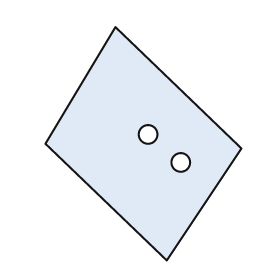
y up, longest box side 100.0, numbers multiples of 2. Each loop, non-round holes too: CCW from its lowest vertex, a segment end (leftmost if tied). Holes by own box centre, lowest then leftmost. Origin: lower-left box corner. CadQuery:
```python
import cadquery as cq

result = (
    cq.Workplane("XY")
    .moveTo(52.0, 0.0)
    .lineTo(84.0, 48.0)
    .lineTo(30.0, 100.0)
    .lineTo(0.0, 50.0)
    .close()
    .moveTo(58.0, 42.0)
    .circle(4.0)
    .moveTo(44.0, 54.0)
    .circle(4.0)
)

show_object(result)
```